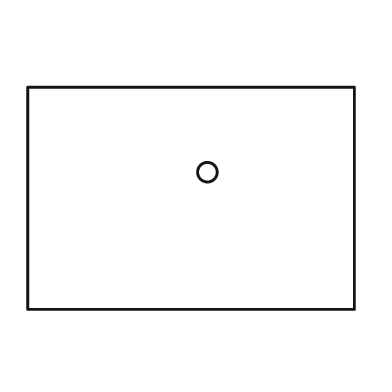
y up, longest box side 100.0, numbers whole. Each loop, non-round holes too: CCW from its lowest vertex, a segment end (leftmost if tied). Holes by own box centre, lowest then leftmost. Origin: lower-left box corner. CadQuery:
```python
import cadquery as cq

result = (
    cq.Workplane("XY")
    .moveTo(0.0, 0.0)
    .lineTo(100.0, 0.0)
    .lineTo(100.0, 68.0)
    .lineTo(0.0, 68.0)
    .close()
    .moveTo(55.0, 42.0)
    .circle(3.0)
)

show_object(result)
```